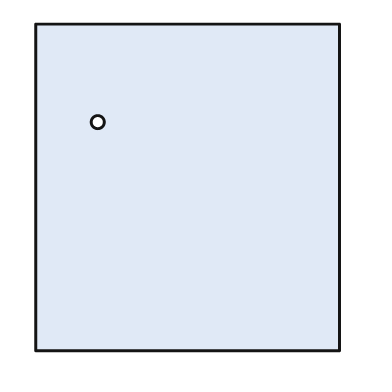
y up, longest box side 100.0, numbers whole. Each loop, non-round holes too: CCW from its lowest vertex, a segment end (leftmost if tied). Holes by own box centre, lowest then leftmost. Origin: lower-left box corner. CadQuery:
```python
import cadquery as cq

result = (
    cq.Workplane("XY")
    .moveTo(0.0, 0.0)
    .lineTo(93.0, 0.0)
    .lineTo(93.0, 100.0)
    .lineTo(0.0, 100.0)
    .close()
    .moveTo(19.0, 70.0)
    .circle(2.0)
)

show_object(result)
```